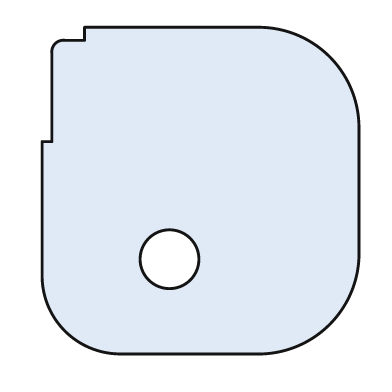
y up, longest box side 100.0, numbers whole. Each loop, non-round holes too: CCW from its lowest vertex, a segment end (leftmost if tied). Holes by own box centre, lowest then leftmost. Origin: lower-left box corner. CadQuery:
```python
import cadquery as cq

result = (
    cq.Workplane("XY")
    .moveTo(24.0, 0.0)
    .lineTo(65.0, 0.0)
    .threePointArc((88.0, 9.0), (97.0, 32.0))
    .lineTo(97.0, 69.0)
    .threePointArc((88.0, 91.0), (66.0, 100.0))
    .lineTo(13.0, 100.0)
    .lineTo(13.0, 96.0)
    .lineTo(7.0, 96.0)
    .threePointArc((4.0, 95.0), (3.0, 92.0))
    .lineTo(3.0, 65.0)
    .lineTo(0.0, 65.0)
    .lineTo(0.0, 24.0)
    .threePointArc((7.0, 7.0), (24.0, 0.0))
    .close()
    .moveTo(39.0, 29.0)
    .circle(9.0)
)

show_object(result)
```